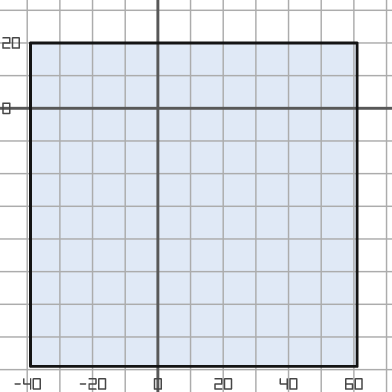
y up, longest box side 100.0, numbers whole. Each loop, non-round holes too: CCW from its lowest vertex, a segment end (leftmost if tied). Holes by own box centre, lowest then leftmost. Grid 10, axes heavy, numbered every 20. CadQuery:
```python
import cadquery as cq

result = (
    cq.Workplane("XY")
    .moveTo(-39.0, -79.0)
    .lineTo(61.0, -79.0)
    .lineTo(61.0, 20.0)
    .lineTo(-39.0, 20.0)
    .close()
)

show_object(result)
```